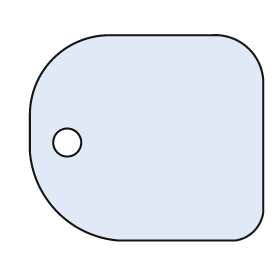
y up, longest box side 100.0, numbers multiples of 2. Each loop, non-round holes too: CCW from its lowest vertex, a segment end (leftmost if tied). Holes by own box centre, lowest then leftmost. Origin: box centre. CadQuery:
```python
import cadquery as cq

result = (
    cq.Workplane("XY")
    .moveTo(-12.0, -44.0)
    .lineTo(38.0, -44.0)
    .threePointArc((46.0, -40.0), (50.0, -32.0))
    .lineTo(50.0, 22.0)
    .threePointArc((44.0, 38.0), (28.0, 44.0))
    .lineTo(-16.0, 44.0)
    .threePointArc((-40.0, 34.0), (-50.0, 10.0))
    .lineTo(-50.0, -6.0)
    .threePointArc((-38.0, -32.0), (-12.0, -44.0))
    .close()
    .moveTo(-34.0, -2.0)
    .circle(6.0)
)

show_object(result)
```